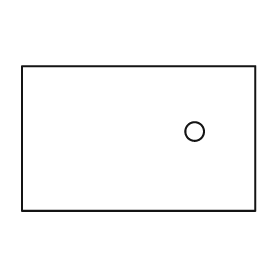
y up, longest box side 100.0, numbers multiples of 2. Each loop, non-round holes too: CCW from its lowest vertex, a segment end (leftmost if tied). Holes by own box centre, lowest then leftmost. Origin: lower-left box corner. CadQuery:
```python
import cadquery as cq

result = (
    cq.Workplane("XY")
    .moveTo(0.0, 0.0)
    .lineTo(100.0, 0.0)
    .lineTo(100.0, 62.0)
    .lineTo(0.0, 62.0)
    .close()
    .moveTo(74.0, 34.0)
    .circle(4.0)
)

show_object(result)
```